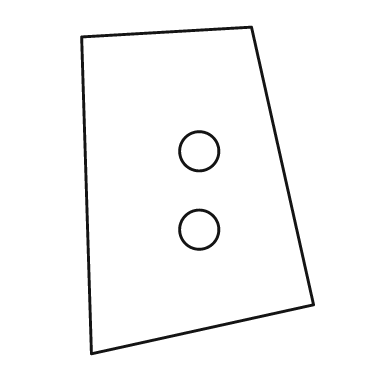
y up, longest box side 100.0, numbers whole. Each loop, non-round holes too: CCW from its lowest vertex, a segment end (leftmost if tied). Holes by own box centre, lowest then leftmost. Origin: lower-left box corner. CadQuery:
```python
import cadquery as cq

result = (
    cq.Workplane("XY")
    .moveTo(3.0, 0.0)
    .lineTo(71.0, 15.0)
    .lineTo(52.0, 100.0)
    .lineTo(0.0, 97.0)
    .close()
    .moveTo(36.0, 38.0)
    .circle(6.0)
    .moveTo(36.0, 62.0)
    .circle(6.0)
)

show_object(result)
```